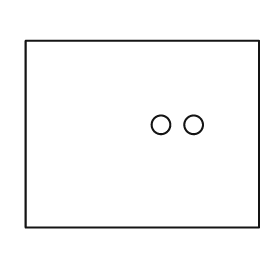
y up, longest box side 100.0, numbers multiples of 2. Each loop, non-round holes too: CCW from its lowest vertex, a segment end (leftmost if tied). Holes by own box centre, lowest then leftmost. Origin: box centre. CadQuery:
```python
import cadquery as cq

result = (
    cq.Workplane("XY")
    .moveTo(-50.0, -40.0)
    .lineTo(50.0, -40.0)
    .lineTo(50.0, 40.0)
    .lineTo(-50.0, 40.0)
    .close()
    .moveTo(8.0, 4.0)
    .circle(4.0)
    .moveTo(22.0, 4.0)
    .circle(4.0)
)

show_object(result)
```